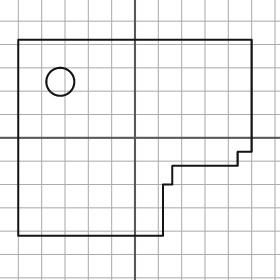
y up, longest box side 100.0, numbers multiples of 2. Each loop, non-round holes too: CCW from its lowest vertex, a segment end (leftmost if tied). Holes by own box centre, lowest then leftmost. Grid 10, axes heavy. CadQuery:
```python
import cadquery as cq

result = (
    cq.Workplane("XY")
    .moveTo(-50.0, -42.0)
    .lineTo(12.0, -42.0)
    .lineTo(12.0, -20.0)
    .lineTo(16.0, -20.0)
    .lineTo(16.0, -12.0)
    .lineTo(44.0, -12.0)
    .lineTo(44.0, -6.0)
    .lineTo(50.0, -6.0)
    .lineTo(50.0, 42.0)
    .lineTo(-50.0, 42.0)
    .close()
    .moveTo(-32.0, 24.0)
    .circle(6.0)
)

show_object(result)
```